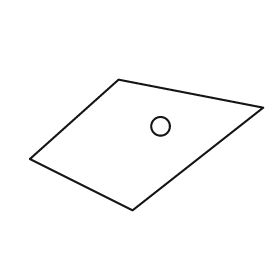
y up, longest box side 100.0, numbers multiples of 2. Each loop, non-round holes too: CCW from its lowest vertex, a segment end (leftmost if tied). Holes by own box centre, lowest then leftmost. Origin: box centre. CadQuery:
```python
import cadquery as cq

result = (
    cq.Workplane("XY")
    .moveTo(-6.0, -28.0)
    .lineTo(50.0, 16.0)
    .lineTo(-12.0, 28.0)
    .lineTo(-50.0, -6.0)
    .close()
    .moveTo(6.0, 8.0)
    .circle(4.0)
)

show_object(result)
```